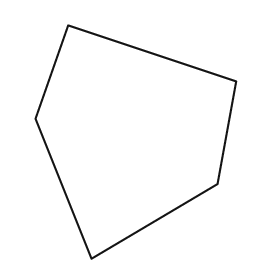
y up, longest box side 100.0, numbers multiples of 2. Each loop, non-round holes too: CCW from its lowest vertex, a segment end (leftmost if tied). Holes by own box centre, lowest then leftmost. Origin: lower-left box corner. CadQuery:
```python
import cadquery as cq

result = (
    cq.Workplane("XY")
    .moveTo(24.0, 0.0)
    .lineTo(78.0, 32.0)
    .lineTo(86.0, 76.0)
    .lineTo(14.0, 100.0)
    .lineTo(0.0, 60.0)
    .close()
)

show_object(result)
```